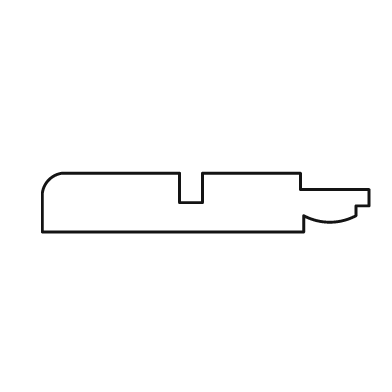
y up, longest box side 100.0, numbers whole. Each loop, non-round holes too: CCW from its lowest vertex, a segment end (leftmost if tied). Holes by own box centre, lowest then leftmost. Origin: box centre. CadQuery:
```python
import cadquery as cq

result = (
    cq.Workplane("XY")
    .moveTo(-50.0, -9.0)
    .lineTo(30.0, -9.0)
    .lineTo(30.0, -4.0)
    .threePointArc((38.0, -6.0), (46.0, -4.0))
    .lineTo(46.0, -1.0)
    .lineTo(50.0, -1.0)
    .lineTo(50.0, 4.0)
    .lineTo(29.0, 4.0)
    .lineTo(29.0, 9.0)
    .lineTo(-1.0, 9.0)
    .lineTo(-1.0, 0.0)
    .lineTo(-8.0, 0.0)
    .lineTo(-8.0, 9.0)
    .lineTo(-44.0, 9.0)
    .threePointArc((-48.0, 7.0), (-50.0, 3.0))
    .close()
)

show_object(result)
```